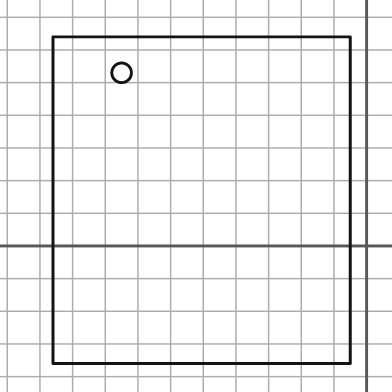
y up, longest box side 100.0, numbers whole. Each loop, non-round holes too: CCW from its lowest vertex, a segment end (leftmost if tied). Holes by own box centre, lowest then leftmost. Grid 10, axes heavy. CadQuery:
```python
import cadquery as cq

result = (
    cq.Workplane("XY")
    .moveTo(-96.0, -36.0)
    .lineTo(-5.0, -36.0)
    .lineTo(-5.0, 64.0)
    .lineTo(-96.0, 64.0)
    .close()
    .moveTo(-75.0, 53.0)
    .circle(3.0)
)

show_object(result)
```